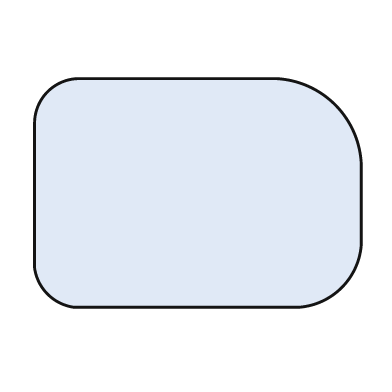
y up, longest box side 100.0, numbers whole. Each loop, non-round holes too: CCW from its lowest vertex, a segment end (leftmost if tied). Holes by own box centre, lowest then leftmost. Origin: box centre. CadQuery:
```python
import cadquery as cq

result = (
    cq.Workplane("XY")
    .moveTo(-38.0, -35.0)
    .lineTo(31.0, -35.0)
    .threePointArc((44.0, -29.0), (50.0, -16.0))
    .lineTo(50.0, 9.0)
    .threePointArc((42.0, 27.0), (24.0, 35.0))
    .lineTo(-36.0, 35.0)
    .threePointArc((-46.0, 31.0), (-50.0, 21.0))
    .lineTo(-50.0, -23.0)
    .threePointArc((-46.0, -31.0), (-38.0, -35.0))
    .close()
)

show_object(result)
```